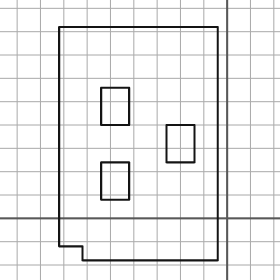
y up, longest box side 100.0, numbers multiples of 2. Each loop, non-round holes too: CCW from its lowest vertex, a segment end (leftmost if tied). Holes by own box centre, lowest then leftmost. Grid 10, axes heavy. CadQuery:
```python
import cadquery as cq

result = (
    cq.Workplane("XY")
    .moveTo(-62.0, -18.0)
    .lineTo(-4.0, -18.0)
    .lineTo(-4.0, 82.0)
    .lineTo(-72.0, 82.0)
    .lineTo(-72.0, -12.0)
    .lineTo(-62.0, -12.0)
    .close()
    .moveTo(-54.0, 8.0)
    .lineTo(-42.0, 8.0)
    .lineTo(-42.0, 24.0)
    .lineTo(-54.0, 24.0)
    .close()
    .moveTo(-26.0, 24.0)
    .lineTo(-14.0, 24.0)
    .lineTo(-14.0, 40.0)
    .lineTo(-26.0, 40.0)
    .close()
    .moveTo(-54.0, 40.0)
    .lineTo(-42.0, 40.0)
    .lineTo(-42.0, 56.0)
    .lineTo(-54.0, 56.0)
    .close()
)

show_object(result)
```